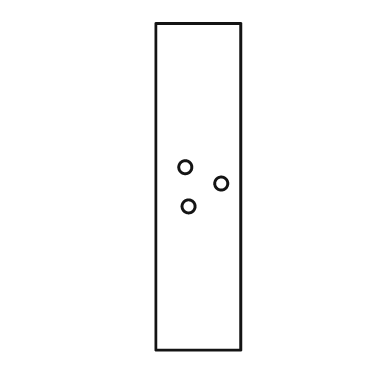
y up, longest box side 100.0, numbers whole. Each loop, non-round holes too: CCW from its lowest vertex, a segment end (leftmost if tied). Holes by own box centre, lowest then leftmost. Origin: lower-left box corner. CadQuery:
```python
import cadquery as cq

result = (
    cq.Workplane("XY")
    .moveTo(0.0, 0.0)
    .lineTo(26.0, 0.0)
    .lineTo(26.0, 100.0)
    .lineTo(0.0, 100.0)
    .close()
    .moveTo(10.0, 44.0)
    .circle(2.0)
    .moveTo(20.0, 51.0)
    .circle(2.0)
    .moveTo(9.0, 56.0)
    .circle(2.0)
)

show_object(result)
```